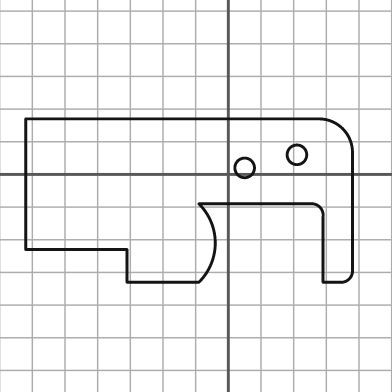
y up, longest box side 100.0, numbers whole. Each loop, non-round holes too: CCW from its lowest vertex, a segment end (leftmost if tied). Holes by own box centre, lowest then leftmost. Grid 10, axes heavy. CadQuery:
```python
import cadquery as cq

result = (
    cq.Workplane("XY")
    .moveTo(-31.0, -33.0)
    .lineTo(-9.0, -33.0)
    .threePointArc((-4.0, -21.0), (-9.0, -9.0))
    .lineTo(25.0, -9.0)
    .threePointArc((28.0, -10.0), (29.0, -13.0))
    .lineTo(29.0, -33.0)
    .lineTo(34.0, -33.0)
    .threePointArc((37.0, -32.0), (38.0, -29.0))
    .lineTo(38.0, 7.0)
    .threePointArc((35.0, 14.0), (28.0, 17.0))
    .lineTo(-62.0, 17.0)
    .lineTo(-62.0, -23.0)
    .lineTo(-31.0, -23.0)
    .close()
    .moveTo(5.0, 2.0)
    .circle(3.0)
    .moveTo(21.0, 6.0)
    .circle(3.0)
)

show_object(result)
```